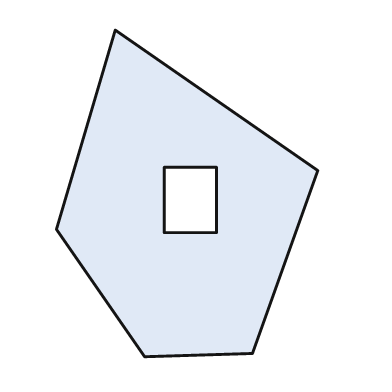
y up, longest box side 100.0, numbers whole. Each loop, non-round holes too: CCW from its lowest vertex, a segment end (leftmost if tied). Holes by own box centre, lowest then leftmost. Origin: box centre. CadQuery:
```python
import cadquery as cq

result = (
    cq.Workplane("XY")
    .moveTo(-13.0, -50.0)
    .lineTo(20.0, -49.0)
    .lineTo(40.0, 7.0)
    .lineTo(-22.0, 50.0)
    .lineTo(-40.0, -11.0)
    .close()
    .moveTo(-7.0, -12.0)
    .lineTo(9.0, -12.0)
    .lineTo(9.0, 8.0)
    .lineTo(-7.0, 8.0)
    .close()
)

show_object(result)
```